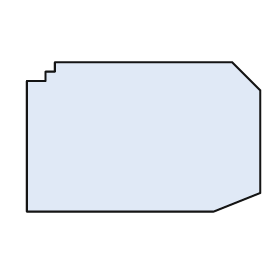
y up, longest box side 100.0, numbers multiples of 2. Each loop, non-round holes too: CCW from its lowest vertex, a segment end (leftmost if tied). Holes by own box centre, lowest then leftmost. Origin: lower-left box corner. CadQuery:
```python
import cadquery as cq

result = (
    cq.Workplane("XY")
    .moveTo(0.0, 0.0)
    .lineTo(80.0, 0.0)
    .lineTo(100.0, 8.0)
    .lineTo(100.0, 52.0)
    .lineTo(88.0, 64.0)
    .lineTo(12.0, 64.0)
    .lineTo(12.0, 60.0)
    .lineTo(8.0, 60.0)
    .lineTo(8.0, 56.0)
    .lineTo(0.0, 56.0)
    .close()
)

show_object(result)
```